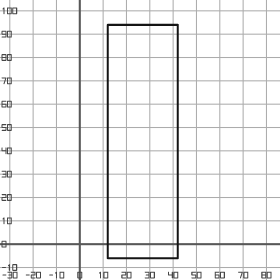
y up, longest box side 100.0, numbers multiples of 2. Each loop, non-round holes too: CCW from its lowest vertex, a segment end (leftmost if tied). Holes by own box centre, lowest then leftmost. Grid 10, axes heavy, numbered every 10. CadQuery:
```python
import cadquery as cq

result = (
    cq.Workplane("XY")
    .moveTo(12.0, -6.0)
    .lineTo(42.0, -6.0)
    .lineTo(42.0, 94.0)
    .lineTo(12.0, 94.0)
    .close()
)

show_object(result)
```